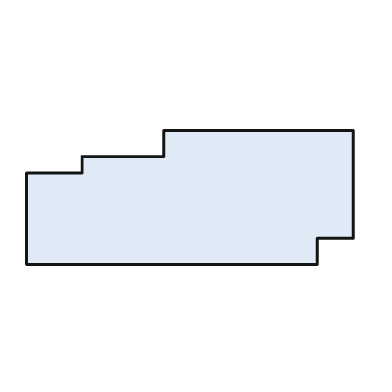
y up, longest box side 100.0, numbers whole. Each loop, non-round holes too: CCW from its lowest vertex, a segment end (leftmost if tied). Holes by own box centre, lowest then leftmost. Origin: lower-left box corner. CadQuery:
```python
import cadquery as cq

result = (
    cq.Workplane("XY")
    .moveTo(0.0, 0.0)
    .lineTo(89.0, 0.0)
    .lineTo(89.0, 8.0)
    .lineTo(100.0, 8.0)
    .lineTo(100.0, 41.0)
    .lineTo(42.0, 41.0)
    .lineTo(42.0, 33.0)
    .lineTo(17.0, 33.0)
    .lineTo(17.0, 28.0)
    .lineTo(0.0, 28.0)
    .close()
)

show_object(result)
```